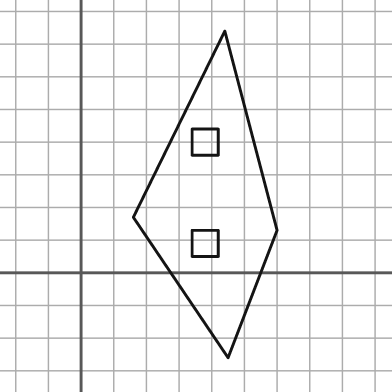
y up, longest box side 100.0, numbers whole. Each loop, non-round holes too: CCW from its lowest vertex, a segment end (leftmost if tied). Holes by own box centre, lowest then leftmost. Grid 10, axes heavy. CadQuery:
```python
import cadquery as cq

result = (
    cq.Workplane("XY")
    .moveTo(45.0, -26.0)
    .lineTo(60.0, 13.0)
    .lineTo(44.0, 74.0)
    .lineTo(16.0, 17.0)
    .close()
    .moveTo(34.0, 5.0)
    .lineTo(42.0, 5.0)
    .lineTo(42.0, 13.0)
    .lineTo(34.0, 13.0)
    .close()
    .moveTo(34.0, 36.0)
    .lineTo(42.0, 36.0)
    .lineTo(42.0, 44.0)
    .lineTo(34.0, 44.0)
    .close()
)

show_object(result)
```